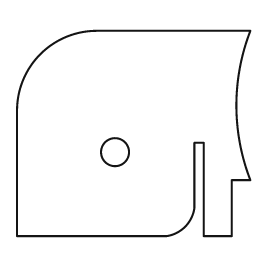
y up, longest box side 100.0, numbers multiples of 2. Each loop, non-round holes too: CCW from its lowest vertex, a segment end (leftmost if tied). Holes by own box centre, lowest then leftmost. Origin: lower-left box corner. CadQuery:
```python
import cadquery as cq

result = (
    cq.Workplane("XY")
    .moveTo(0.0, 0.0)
    .lineTo(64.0, 0.0)
    .threePointArc((72.0, 4.0), (76.0, 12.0))
    .lineTo(76.0, 40.0)
    .lineTo(80.0, 40.0)
    .lineTo(80.0, 0.0)
    .lineTo(92.0, 0.0)
    .lineTo(92.0, 24.0)
    .lineTo(100.0, 24.0)
    .threePointArc((94.0, 56.0), (100.0, 88.0))
    .lineTo(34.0, 88.0)
    .threePointArc((10.0, 78.0), (0.0, 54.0))
    .close()
    .moveTo(42.0, 36.0)
    .circle(6.0)
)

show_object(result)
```